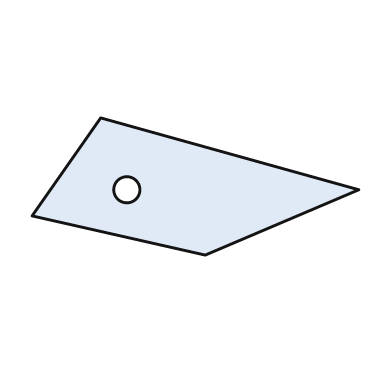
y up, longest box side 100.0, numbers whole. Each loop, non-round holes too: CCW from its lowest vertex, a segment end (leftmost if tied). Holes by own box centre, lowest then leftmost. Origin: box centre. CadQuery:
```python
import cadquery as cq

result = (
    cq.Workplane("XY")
    .moveTo(3.0, -21.0)
    .lineTo(50.0, -1.0)
    .lineTo(-29.0, 21.0)
    .lineTo(-50.0, -9.0)
    .close()
    .moveTo(-21.0, -1.0)
    .circle(4.0)
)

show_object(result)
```